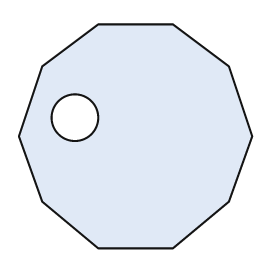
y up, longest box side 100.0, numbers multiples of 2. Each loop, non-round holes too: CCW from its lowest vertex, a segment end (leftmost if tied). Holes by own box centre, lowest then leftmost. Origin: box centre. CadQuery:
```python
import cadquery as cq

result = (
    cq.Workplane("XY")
    .moveTo(-16.0, -48.0)
    .lineTo(16.0, -48.0)
    .lineTo(40.0, -28.0)
    .lineTo(50.0, 0.0)
    .lineTo(40.0, 30.0)
    .lineTo(16.0, 48.0)
    .lineTo(-16.0, 48.0)
    .lineTo(-40.0, 30.0)
    .lineTo(-50.0, 0.0)
    .lineTo(-40.0, -28.0)
    .close()
    .moveTo(-26.0, 8.0)
    .circle(10.0)
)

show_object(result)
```